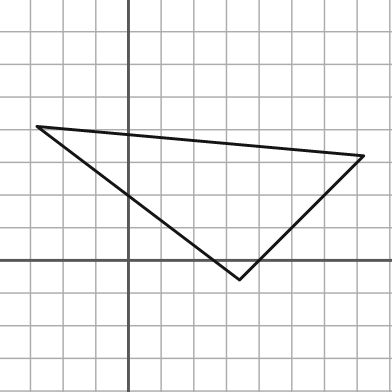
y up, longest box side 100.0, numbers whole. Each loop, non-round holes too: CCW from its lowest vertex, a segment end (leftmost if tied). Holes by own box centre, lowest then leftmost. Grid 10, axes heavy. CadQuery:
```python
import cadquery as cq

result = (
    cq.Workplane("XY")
    .moveTo(34.0, -6.0)
    .lineTo(72.0, 32.0)
    .lineTo(-28.0, 41.0)
    .close()
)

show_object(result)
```